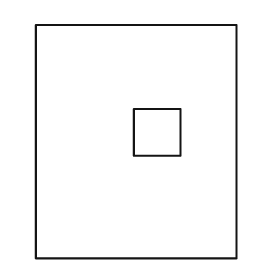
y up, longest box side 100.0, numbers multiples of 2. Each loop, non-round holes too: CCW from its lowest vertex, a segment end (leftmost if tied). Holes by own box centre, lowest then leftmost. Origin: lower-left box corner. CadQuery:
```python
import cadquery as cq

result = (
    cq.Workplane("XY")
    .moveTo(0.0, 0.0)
    .lineTo(86.0, 0.0)
    .lineTo(86.0, 100.0)
    .lineTo(0.0, 100.0)
    .close()
    .moveTo(42.0, 44.0)
    .lineTo(62.0, 44.0)
    .lineTo(62.0, 64.0)
    .lineTo(42.0, 64.0)
    .close()
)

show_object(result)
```